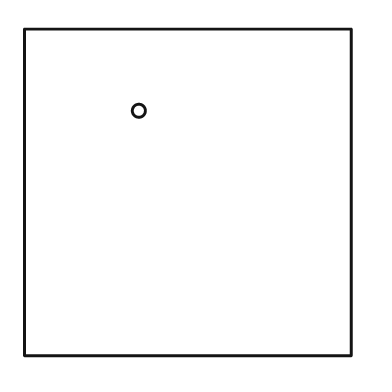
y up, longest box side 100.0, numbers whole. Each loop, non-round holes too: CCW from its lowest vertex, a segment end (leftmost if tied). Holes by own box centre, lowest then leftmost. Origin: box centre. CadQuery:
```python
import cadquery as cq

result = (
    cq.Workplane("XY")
    .moveTo(-50.0, -50.0)
    .lineTo(50.0, -50.0)
    .lineTo(50.0, 50.0)
    .lineTo(-50.0, 50.0)
    .close()
    .moveTo(-15.0, 25.0)
    .circle(2.0)
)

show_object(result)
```